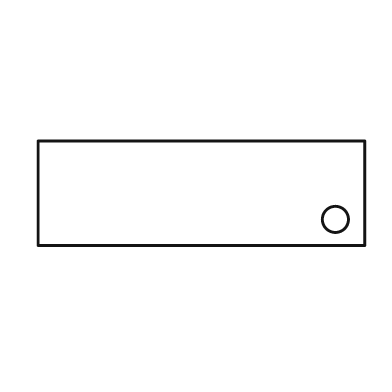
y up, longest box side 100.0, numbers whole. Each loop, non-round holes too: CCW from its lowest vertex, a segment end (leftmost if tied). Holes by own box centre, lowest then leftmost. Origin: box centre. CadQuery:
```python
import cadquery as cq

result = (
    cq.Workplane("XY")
    .moveTo(-50.0, -16.0)
    .lineTo(50.0, -16.0)
    .lineTo(50.0, 16.0)
    .lineTo(-50.0, 16.0)
    .close()
    .moveTo(41.0, -8.0)
    .circle(4.0)
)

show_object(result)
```